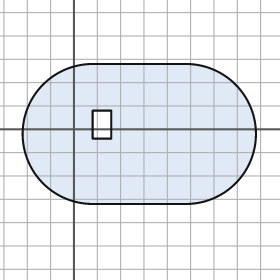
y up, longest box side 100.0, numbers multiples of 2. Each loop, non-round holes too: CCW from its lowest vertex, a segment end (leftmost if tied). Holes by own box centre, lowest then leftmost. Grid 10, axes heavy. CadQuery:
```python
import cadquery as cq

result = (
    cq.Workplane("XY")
    .moveTo(8.0, -32.0)
    .lineTo(48.0, -32.0)
    .threePointArc((78.0, -2.0), (48.0, 28.0))
    .lineTo(8.0, 28.0)
    .threePointArc((-22.0, -2.0), (8.0, -32.0))
    .close()
    .moveTo(8.0, -4.0)
    .lineTo(16.0, -4.0)
    .lineTo(16.0, 8.0)
    .lineTo(8.0, 8.0)
    .close()
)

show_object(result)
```